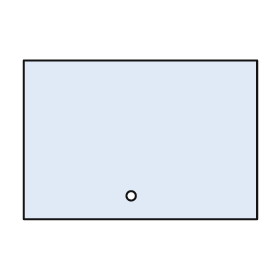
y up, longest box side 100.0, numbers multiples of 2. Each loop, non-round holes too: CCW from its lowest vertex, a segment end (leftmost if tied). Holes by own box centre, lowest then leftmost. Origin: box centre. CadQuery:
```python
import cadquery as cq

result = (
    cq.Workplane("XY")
    .moveTo(-50.0, -34.0)
    .lineTo(50.0, -34.0)
    .lineTo(50.0, 34.0)
    .lineTo(-50.0, 34.0)
    .close()
    .moveTo(-4.0, -24.0)
    .circle(2.0)
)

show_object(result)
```